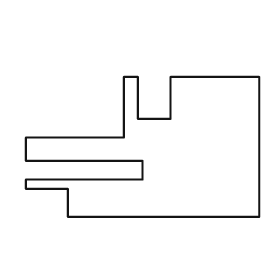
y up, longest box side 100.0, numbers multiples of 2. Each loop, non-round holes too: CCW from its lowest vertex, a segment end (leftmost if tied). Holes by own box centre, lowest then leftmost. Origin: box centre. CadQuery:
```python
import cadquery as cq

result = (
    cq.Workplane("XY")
    .moveTo(-32.0, -30.0)
    .lineTo(50.0, -30.0)
    .lineTo(50.0, 30.0)
    .lineTo(12.0, 30.0)
    .lineTo(12.0, 12.0)
    .lineTo(-2.0, 12.0)
    .lineTo(-2.0, 30.0)
    .lineTo(-8.0, 30.0)
    .lineTo(-8.0, 4.0)
    .lineTo(-50.0, 4.0)
    .lineTo(-50.0, -6.0)
    .lineTo(0.0, -6.0)
    .lineTo(0.0, -14.0)
    .lineTo(-50.0, -14.0)
    .lineTo(-50.0, -18.0)
    .lineTo(-32.0, -18.0)
    .close()
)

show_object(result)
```